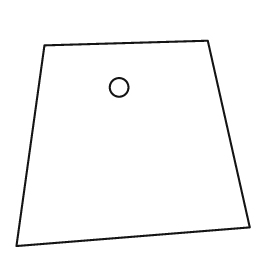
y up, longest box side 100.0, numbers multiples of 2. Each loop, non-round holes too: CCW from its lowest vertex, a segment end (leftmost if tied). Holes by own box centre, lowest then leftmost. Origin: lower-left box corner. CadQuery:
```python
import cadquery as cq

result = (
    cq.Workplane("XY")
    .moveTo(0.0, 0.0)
    .lineTo(100.0, 8.0)
    .lineTo(82.0, 88.0)
    .lineTo(12.0, 86.0)
    .close()
    .moveTo(44.0, 68.0)
    .circle(4.0)
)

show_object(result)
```